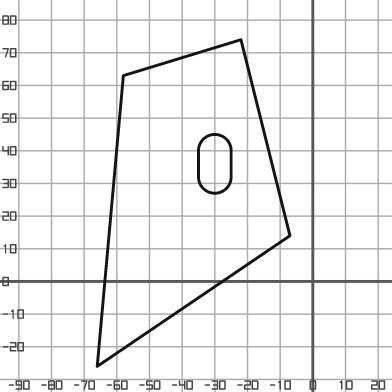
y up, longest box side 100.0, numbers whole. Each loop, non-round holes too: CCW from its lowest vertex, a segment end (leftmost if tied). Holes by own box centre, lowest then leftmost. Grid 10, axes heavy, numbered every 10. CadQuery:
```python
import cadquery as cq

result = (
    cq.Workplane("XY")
    .moveTo(-66.0, -26.0)
    .lineTo(-7.0, 14.0)
    .lineTo(-22.0, 74.0)
    .lineTo(-58.0, 63.0)
    .close()
    .moveTo(-35.0, 32.0)
    .threePointArc((-30.0, 27.0), (-25.0, 32.0))
    .lineTo(-25.0, 40.0)
    .threePointArc((-30.0, 45.0), (-35.0, 40.0))
    .close()
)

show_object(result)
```